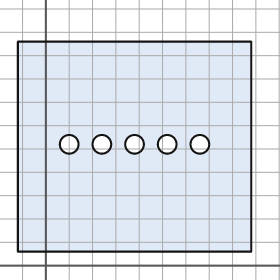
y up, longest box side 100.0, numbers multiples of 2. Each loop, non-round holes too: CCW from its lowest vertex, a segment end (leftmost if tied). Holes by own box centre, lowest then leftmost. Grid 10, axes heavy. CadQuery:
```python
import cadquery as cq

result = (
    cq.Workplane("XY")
    .moveTo(-12.0, 6.0)
    .lineTo(88.0, 6.0)
    .lineTo(88.0, 96.0)
    .lineTo(-12.0, 96.0)
    .close()
    .moveTo(10.0, 52.0)
    .circle(4.0)
    .moveTo(24.0, 52.0)
    .circle(4.0)
    .moveTo(38.0, 52.0)
    .circle(4.0)
    .moveTo(52.0, 52.0)
    .circle(4.0)
    .moveTo(66.0, 52.0)
    .circle(4.0)
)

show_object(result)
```